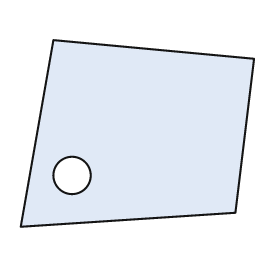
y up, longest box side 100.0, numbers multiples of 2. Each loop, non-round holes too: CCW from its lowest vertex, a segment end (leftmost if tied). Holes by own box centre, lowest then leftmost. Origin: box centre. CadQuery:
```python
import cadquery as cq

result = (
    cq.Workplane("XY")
    .moveTo(-50.0, -40.0)
    .lineTo(42.0, -34.0)
    .lineTo(50.0, 32.0)
    .lineTo(-36.0, 40.0)
    .close()
    .moveTo(-28.0, -18.0)
    .circle(8.0)
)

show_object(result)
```